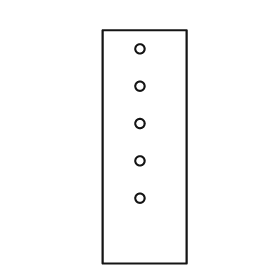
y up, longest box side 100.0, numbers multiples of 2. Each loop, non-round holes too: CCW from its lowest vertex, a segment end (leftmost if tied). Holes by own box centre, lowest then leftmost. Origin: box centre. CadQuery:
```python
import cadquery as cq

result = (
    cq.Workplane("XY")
    .moveTo(-18.0, -50.0)
    .lineTo(18.0, -50.0)
    .lineTo(18.0, 50.0)
    .lineTo(-18.0, 50.0)
    .close()
    .moveTo(-2.0, -22.0)
    .circle(2.0)
    .moveTo(-2.0, -6.0)
    .circle(2.0)
    .moveTo(-2.0, 10.0)
    .circle(2.0)
    .moveTo(-2.0, 26.0)
    .circle(2.0)
    .moveTo(-2.0, 42.0)
    .circle(2.0)
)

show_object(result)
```